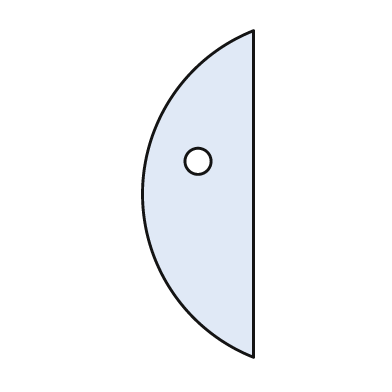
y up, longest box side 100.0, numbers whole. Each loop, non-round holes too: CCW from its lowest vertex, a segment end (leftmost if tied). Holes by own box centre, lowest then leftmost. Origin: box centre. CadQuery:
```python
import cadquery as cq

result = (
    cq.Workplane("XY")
    .moveTo(17.0, -50.0)
    .lineTo(17.0, 50.0)
    .threePointArc((-17.0, 0.0), (17.0, -50.0))
    .close()
    .moveTo(0.0, 10.0)
    .circle(4.0)
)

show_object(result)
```